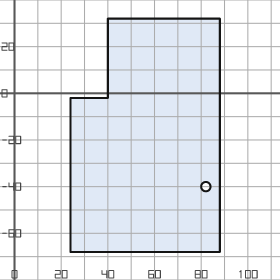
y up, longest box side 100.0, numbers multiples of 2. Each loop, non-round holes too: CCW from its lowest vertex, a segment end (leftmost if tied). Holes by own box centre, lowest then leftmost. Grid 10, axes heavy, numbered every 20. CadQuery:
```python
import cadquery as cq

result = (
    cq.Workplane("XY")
    .moveTo(24.0, -68.0)
    .lineTo(88.0, -68.0)
    .lineTo(88.0, 32.0)
    .lineTo(40.0, 32.0)
    .lineTo(40.0, -2.0)
    .lineTo(24.0, -2.0)
    .close()
    .moveTo(82.0, -40.0)
    .circle(2.0)
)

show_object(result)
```